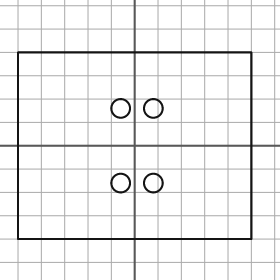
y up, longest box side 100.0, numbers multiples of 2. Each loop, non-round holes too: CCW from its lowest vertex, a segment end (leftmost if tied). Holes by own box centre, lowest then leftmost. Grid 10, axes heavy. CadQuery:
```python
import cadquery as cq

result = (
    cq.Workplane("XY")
    .moveTo(-50.0, -40.0)
    .lineTo(50.0, -40.0)
    .lineTo(50.0, 40.0)
    .lineTo(-50.0, 40.0)
    .close()
    .moveTo(-6.0, -16.0)
    .circle(4.0)
    .moveTo(8.0, -16.0)
    .circle(4.0)
    .moveTo(-6.0, 16.0)
    .circle(4.0)
    .moveTo(8.0, 16.0)
    .circle(4.0)
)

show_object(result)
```